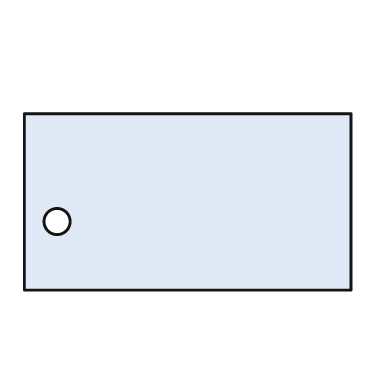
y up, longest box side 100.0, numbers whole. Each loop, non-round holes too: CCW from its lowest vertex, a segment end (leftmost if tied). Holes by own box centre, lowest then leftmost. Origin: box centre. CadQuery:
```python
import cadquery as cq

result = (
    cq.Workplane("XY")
    .moveTo(-50.0, -27.0)
    .lineTo(50.0, -27.0)
    .lineTo(50.0, 27.0)
    .lineTo(-50.0, 27.0)
    .close()
    .moveTo(-40.0, -6.0)
    .circle(4.0)
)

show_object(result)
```